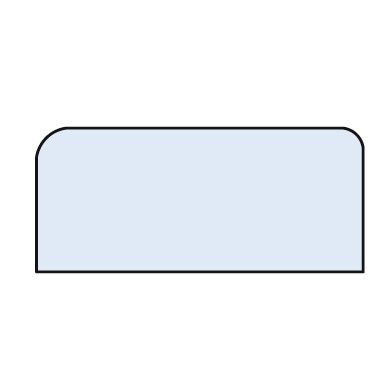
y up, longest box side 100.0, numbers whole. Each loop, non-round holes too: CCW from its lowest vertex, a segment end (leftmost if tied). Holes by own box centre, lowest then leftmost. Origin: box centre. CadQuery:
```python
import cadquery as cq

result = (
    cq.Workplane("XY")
    .moveTo(-50.0, -22.0)
    .lineTo(50.0, -22.0)
    .lineTo(50.0, 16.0)
    .threePointArc((48.0, 20.0), (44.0, 22.0))
    .lineTo(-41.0, 22.0)
    .threePointArc((-47.0, 19.0), (-50.0, 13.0))
    .close()
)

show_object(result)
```